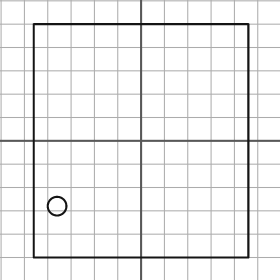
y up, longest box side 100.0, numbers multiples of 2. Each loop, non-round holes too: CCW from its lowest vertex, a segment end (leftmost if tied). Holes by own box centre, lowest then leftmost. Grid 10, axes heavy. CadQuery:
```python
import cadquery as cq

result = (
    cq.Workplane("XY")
    .moveTo(-46.0, -50.0)
    .lineTo(46.0, -50.0)
    .lineTo(46.0, 50.0)
    .lineTo(-46.0, 50.0)
    .close()
    .moveTo(-36.0, -28.0)
    .circle(4.0)
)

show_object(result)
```